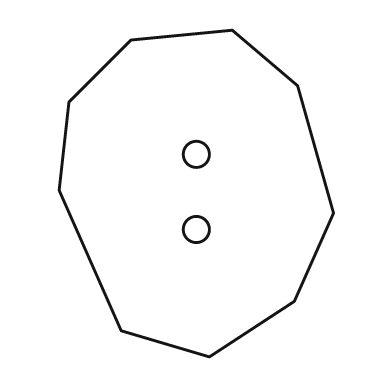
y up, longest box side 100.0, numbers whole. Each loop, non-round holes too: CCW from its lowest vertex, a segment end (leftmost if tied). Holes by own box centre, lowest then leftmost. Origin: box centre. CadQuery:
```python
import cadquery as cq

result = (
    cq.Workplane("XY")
    .moveTo(4.0, -50.0)
    .lineTo(30.0, -33.0)
    .lineTo(42.0, -6.0)
    .lineTo(31.0, 33.0)
    .lineTo(11.0, 50.0)
    .lineTo(-20.0, 47.0)
    .lineTo(-39.0, 28.0)
    .lineTo(-42.0, 1.0)
    .lineTo(-23.0, -42.0)
    .close()
    .moveTo(0.0, -11.0)
    .circle(4.0)
    .moveTo(0.0, 12.0)
    .circle(4.0)
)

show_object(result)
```